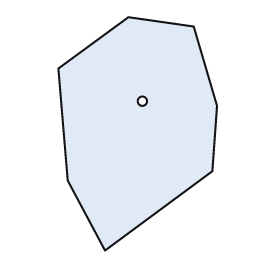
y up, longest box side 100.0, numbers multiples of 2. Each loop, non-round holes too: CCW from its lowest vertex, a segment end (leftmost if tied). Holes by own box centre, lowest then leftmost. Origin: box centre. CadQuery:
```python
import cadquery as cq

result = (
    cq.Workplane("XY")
    .moveTo(-14.0, -50.0)
    .lineTo(32.0, -16.0)
    .lineTo(34.0, 12.0)
    .lineTo(24.0, 46.0)
    .lineTo(-4.0, 50.0)
    .lineTo(-34.0, 28.0)
    .lineTo(-30.0, -20.0)
    .close()
    .moveTo(2.0, 14.0)
    .circle(2.0)
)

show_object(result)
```